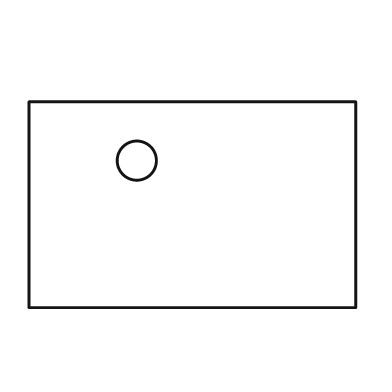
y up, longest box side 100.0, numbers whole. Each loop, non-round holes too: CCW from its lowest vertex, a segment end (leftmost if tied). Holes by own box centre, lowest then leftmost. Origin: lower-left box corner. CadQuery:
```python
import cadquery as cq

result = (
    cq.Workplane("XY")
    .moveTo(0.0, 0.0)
    .lineTo(100.0, 0.0)
    .lineTo(100.0, 63.0)
    .lineTo(0.0, 63.0)
    .close()
    .moveTo(33.0, 45.0)
    .circle(6.0)
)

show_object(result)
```